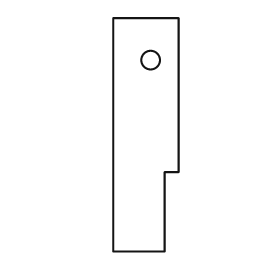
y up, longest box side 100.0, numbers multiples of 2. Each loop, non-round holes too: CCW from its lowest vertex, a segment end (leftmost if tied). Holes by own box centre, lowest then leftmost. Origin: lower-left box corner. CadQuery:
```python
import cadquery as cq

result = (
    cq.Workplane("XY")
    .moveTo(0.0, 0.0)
    .lineTo(22.0, 0.0)
    .lineTo(22.0, 34.0)
    .lineTo(28.0, 34.0)
    .lineTo(28.0, 100.0)
    .lineTo(0.0, 100.0)
    .close()
    .moveTo(16.0, 82.0)
    .circle(4.0)
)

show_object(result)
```